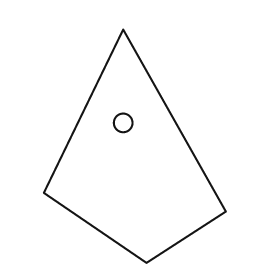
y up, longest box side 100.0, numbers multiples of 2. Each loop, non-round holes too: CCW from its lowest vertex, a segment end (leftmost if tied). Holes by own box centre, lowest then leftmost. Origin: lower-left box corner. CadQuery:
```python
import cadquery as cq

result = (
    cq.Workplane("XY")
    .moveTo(44.0, 0.0)
    .lineTo(78.0, 22.0)
    .lineTo(34.0, 100.0)
    .lineTo(0.0, 30.0)
    .close()
    .moveTo(34.0, 60.0)
    .circle(4.0)
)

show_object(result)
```